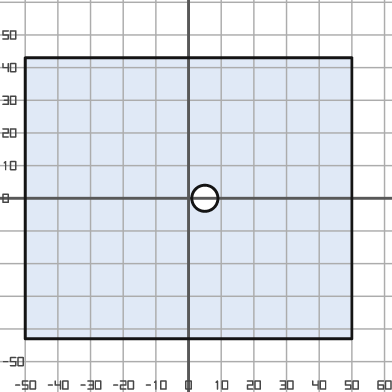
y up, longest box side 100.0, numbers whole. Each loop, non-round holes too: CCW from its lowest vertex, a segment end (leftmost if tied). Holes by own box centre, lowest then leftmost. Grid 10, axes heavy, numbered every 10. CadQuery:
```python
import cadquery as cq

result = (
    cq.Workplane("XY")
    .moveTo(-50.0, -43.0)
    .lineTo(50.0, -43.0)
    .lineTo(50.0, 43.0)
    .lineTo(-50.0, 43.0)
    .close()
    .moveTo(5.0, 0.0)
    .circle(4.0)
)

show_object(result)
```